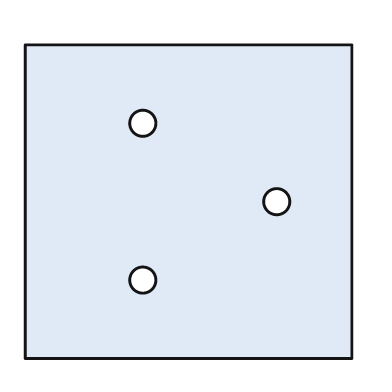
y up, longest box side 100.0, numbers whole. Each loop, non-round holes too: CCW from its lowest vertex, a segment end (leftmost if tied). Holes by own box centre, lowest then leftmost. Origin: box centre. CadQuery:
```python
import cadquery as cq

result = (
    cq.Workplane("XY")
    .moveTo(-50.0, -48.0)
    .lineTo(50.0, -48.0)
    .lineTo(50.0, 48.0)
    .lineTo(-50.0, 48.0)
    .close()
    .moveTo(-14.0, -24.0)
    .circle(4.0)
    .moveTo(27.0, 0.0)
    .circle(4.0)
    .moveTo(-14.0, 24.0)
    .circle(4.0)
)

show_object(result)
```